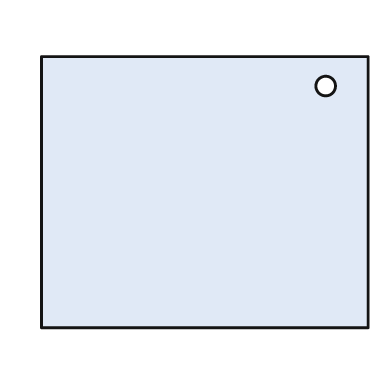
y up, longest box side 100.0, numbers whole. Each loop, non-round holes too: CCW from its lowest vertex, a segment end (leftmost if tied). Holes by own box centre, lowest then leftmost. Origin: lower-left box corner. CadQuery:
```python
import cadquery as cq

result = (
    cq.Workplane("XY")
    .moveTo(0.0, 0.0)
    .lineTo(100.0, 0.0)
    .lineTo(100.0, 83.0)
    .lineTo(0.0, 83.0)
    .close()
    .moveTo(87.0, 74.0)
    .circle(3.0)
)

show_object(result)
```